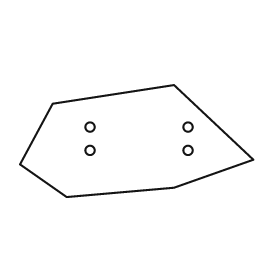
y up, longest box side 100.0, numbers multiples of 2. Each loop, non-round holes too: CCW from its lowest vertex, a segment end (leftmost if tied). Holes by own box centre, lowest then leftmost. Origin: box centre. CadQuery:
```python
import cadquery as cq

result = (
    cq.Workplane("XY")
    .moveTo(-30.0, -24.0)
    .lineTo(16.0, -20.0)
    .lineTo(50.0, -8.0)
    .lineTo(16.0, 24.0)
    .lineTo(-36.0, 16.0)
    .lineTo(-50.0, -10.0)
    .close()
    .moveTo(-20.0, -4.0)
    .circle(2.0)
    .moveTo(22.0, -4.0)
    .circle(2.0)
    .moveTo(-20.0, 6.0)
    .circle(2.0)
    .moveTo(22.0, 6.0)
    .circle(2.0)
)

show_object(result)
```